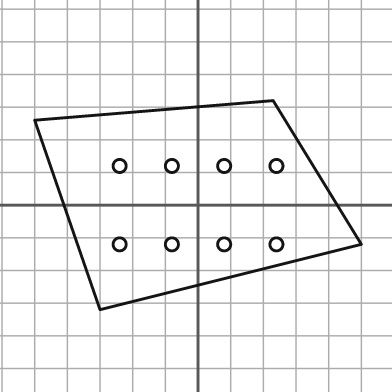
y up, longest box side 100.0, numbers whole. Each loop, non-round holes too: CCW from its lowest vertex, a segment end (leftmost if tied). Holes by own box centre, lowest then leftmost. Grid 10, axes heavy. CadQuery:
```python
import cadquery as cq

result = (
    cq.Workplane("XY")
    .moveTo(-30.0, -32.0)
    .lineTo(50.0, -12.0)
    .lineTo(23.0, 32.0)
    .lineTo(-50.0, 26.0)
    .close()
    .moveTo(-24.0, -12.0)
    .circle(2.0)
    .moveTo(-8.0, -12.0)
    .circle(2.0)
    .moveTo(8.0, -12.0)
    .circle(2.0)
    .moveTo(24.0, -12.0)
    .circle(2.0)
    .moveTo(-24.0, 12.0)
    .circle(2.0)
    .moveTo(-8.0, 12.0)
    .circle(2.0)
    .moveTo(8.0, 12.0)
    .circle(2.0)
    .moveTo(24.0, 12.0)
    .circle(2.0)
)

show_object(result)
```